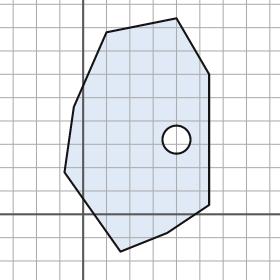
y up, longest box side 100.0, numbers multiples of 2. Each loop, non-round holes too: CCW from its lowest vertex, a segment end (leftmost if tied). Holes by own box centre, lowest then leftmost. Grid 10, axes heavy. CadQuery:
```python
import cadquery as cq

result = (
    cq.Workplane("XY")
    .moveTo(16.0, -16.0)
    .lineTo(36.0, -8.0)
    .lineTo(54.0, 4.0)
    .lineTo(54.0, 60.0)
    .lineTo(40.0, 84.0)
    .lineTo(10.0, 78.0)
    .lineTo(-4.0, 46.0)
    .lineTo(-8.0, 18.0)
    .close()
    .moveTo(40.0, 32.0)
    .circle(6.0)
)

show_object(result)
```